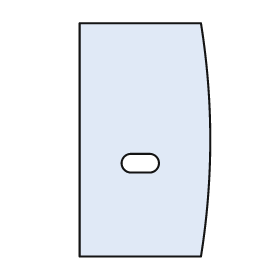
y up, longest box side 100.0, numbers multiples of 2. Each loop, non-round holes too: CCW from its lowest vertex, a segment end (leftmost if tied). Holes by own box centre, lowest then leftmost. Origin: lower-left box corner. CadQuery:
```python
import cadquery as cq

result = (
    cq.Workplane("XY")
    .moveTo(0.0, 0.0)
    .lineTo(52.0, 0.0)
    .threePointArc((56.0, 50.0), (52.0, 100.0))
    .lineTo(0.0, 100.0)
    .close()
    .moveTo(22.0, 36.0)
    .lineTo(30.0, 36.0)
    .threePointArc((34.0, 40.0), (30.0, 44.0))
    .lineTo(22.0, 44.0)
    .threePointArc((18.0, 40.0), (22.0, 36.0))
    .close()
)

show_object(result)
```